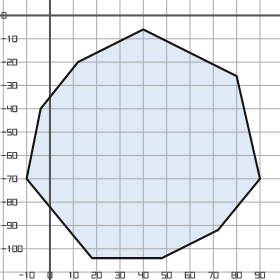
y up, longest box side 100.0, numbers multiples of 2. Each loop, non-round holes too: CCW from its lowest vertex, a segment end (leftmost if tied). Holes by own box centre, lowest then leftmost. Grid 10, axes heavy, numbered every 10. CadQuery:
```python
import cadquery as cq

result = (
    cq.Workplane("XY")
    .moveTo(18.0, -104.0)
    .lineTo(48.0, -104.0)
    .lineTo(72.0, -92.0)
    .lineTo(90.0, -70.0)
    .lineTo(80.0, -26.0)
    .lineTo(40.0, -6.0)
    .lineTo(12.0, -20.0)
    .lineTo(-4.0, -40.0)
    .lineTo(-10.0, -70.0)
    .close()
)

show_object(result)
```